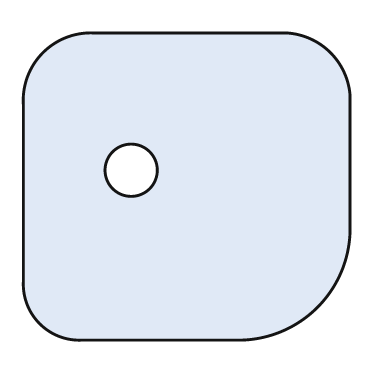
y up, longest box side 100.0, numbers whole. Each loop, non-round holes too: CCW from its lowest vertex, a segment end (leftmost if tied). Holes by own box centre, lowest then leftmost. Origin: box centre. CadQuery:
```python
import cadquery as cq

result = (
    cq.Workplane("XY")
    .moveTo(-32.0, -47.0)
    .lineTo(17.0, -47.0)
    .threePointArc((40.0, -37.0), (50.0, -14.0))
    .lineTo(50.0, 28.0)
    .threePointArc((44.0, 41.0), (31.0, 47.0))
    .lineTo(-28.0, 47.0)
    .threePointArc((-44.0, 41.0), (-50.0, 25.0))
    .lineTo(-50.0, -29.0)
    .threePointArc((-45.0, -42.0), (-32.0, -47.0))
    .close()
    .moveTo(-17.0, 5.0)
    .circle(8.0)
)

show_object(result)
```